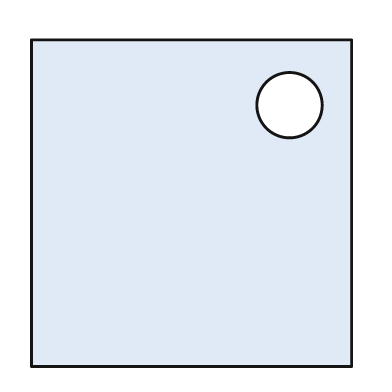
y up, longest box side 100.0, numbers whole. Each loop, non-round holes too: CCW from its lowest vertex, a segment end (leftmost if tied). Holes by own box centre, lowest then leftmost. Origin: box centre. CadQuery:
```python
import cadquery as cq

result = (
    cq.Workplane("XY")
    .moveTo(-49.0, -50.0)
    .lineTo(49.0, -50.0)
    .lineTo(49.0, 50.0)
    .lineTo(-49.0, 50.0)
    .close()
    .moveTo(30.0, 30.0)
    .circle(10.0)
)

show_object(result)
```